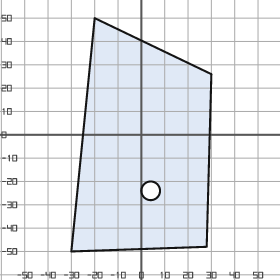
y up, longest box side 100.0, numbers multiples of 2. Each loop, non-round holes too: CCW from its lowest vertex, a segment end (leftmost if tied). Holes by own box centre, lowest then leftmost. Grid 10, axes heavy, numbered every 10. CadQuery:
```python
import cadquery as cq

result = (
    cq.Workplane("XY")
    .moveTo(-30.0, -50.0)
    .lineTo(28.0, -48.0)
    .lineTo(30.0, 26.0)
    .lineTo(-20.0, 50.0)
    .close()
    .moveTo(4.0, -24.0)
    .circle(4.0)
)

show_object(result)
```